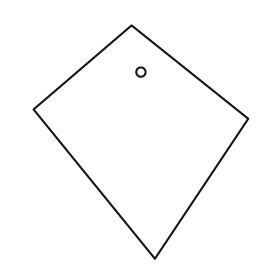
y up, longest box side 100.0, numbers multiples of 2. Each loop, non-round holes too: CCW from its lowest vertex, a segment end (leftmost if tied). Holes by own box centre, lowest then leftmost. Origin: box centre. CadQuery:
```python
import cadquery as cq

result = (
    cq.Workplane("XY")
    .moveTo(6.0, -50.0)
    .lineTo(46.0, 10.0)
    .lineTo(-4.0, 50.0)
    .lineTo(-46.0, 14.0)
    .close()
    .moveTo(0.0, 30.0)
    .circle(2.0)
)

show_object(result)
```